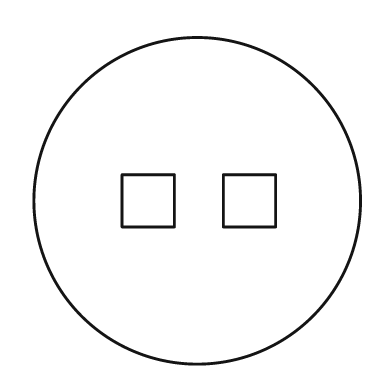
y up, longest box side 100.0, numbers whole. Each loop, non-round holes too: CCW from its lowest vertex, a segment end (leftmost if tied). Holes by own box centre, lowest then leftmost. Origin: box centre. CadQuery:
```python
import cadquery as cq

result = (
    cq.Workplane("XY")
    .moveTo(0.0, 0.0)
    .circle(50.0)
    .moveTo(-23.0, -8.0)
    .lineTo(-7.0, -8.0)
    .lineTo(-7.0, 8.0)
    .lineTo(-23.0, 8.0)
    .close()
    .moveTo(8.0, -8.0)
    .lineTo(24.0, -8.0)
    .lineTo(24.0, 8.0)
    .lineTo(8.0, 8.0)
    .close()
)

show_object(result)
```